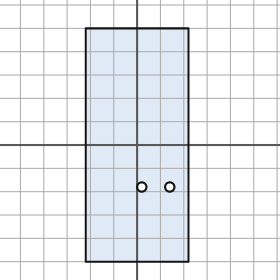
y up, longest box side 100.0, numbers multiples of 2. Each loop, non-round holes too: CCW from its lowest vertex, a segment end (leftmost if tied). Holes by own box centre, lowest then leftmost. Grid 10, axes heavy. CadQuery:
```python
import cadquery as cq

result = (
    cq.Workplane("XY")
    .moveTo(-22.0, -50.0)
    .lineTo(22.0, -50.0)
    .lineTo(22.0, 50.0)
    .lineTo(-22.0, 50.0)
    .close()
    .moveTo(2.0, -18.0)
    .circle(2.0)
    .moveTo(14.0, -18.0)
    .circle(2.0)
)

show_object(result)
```